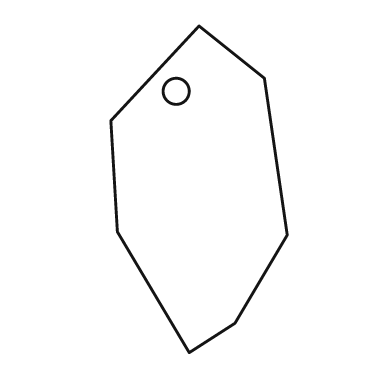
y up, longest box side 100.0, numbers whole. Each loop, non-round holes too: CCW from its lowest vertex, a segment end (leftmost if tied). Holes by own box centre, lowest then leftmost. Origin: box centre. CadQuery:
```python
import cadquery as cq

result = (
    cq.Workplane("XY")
    .moveTo(-3.0, -50.0)
    .lineTo(11.0, -41.0)
    .lineTo(27.0, -14.0)
    .lineTo(20.0, 34.0)
    .lineTo(0.0, 50.0)
    .lineTo(-27.0, 21.0)
    .lineTo(-25.0, -13.0)
    .close()
    .moveTo(-7.0, 30.0)
    .circle(4.0)
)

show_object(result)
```